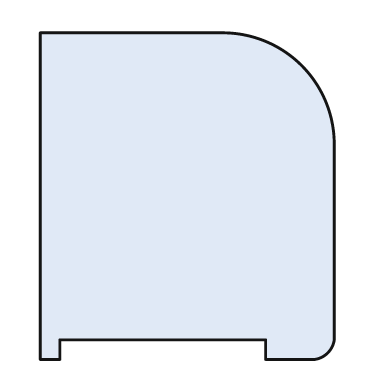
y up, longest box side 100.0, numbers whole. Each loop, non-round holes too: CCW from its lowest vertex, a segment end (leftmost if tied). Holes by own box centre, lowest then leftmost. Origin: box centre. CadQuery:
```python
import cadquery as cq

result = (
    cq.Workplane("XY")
    .moveTo(-45.0, -50.0)
    .lineTo(-39.0, -50.0)
    .lineTo(-39.0, -44.0)
    .lineTo(24.0, -44.0)
    .lineTo(24.0, -50.0)
    .lineTo(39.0, -50.0)
    .threePointArc((43.0, -48.0), (45.0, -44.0))
    .lineTo(45.0, 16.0)
    .threePointArc((35.0, 40.0), (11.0, 50.0))
    .lineTo(-45.0, 50.0)
    .close()
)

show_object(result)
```